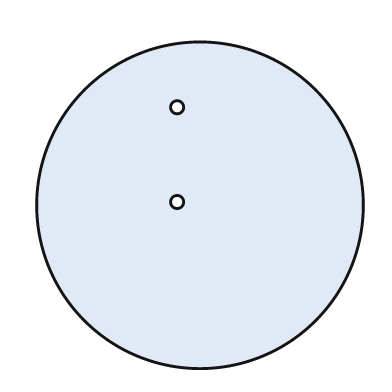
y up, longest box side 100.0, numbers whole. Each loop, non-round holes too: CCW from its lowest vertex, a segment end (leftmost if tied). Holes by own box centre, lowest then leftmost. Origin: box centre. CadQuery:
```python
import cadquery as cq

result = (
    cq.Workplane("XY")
    .moveTo(0.0, 0.0)
    .circle(50.0)
    .moveTo(-7.0, 1.0)
    .circle(2.0)
    .moveTo(-7.0, 30.0)
    .circle(2.0)
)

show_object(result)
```